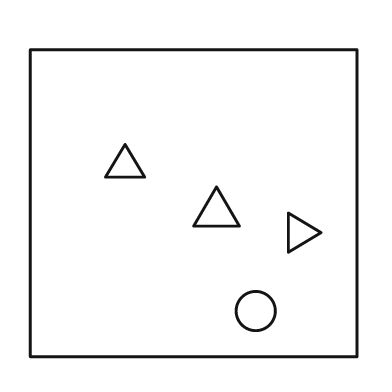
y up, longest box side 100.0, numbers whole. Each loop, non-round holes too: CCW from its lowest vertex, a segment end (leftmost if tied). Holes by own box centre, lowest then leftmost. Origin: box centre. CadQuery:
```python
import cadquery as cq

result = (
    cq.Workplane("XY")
    .moveTo(-50.0, -47.0)
    .lineTo(50.0, -47.0)
    .lineTo(50.0, 47.0)
    .lineTo(-50.0, 47.0)
    .close()
    .moveTo(19.0, -33.0)
    .circle(6.0)
    .moveTo(29.0, -15.0)
    .lineTo(39.0, -9.0)
    .lineTo(29.0, -3.0)
    .close()
    .moveTo(0.0, -7.0)
    .lineTo(14.0, -7.0)
    .lineTo(7.0, 5.0)
    .close()
    .moveTo(-27.0, 8.0)
    .lineTo(-15.0, 8.0)
    .lineTo(-21.0, 18.0)
    .close()
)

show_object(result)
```